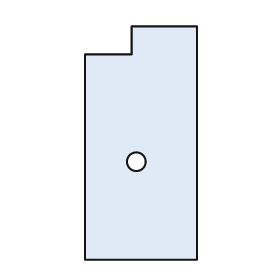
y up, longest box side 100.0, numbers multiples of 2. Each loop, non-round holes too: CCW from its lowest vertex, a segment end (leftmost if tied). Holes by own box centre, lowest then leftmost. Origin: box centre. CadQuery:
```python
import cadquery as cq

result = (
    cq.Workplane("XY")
    .moveTo(-24.0, -50.0)
    .lineTo(24.0, -50.0)
    .lineTo(24.0, 50.0)
    .lineTo(-4.0, 50.0)
    .lineTo(-4.0, 38.0)
    .lineTo(-24.0, 38.0)
    .close()
    .moveTo(-2.0, -8.0)
    .circle(4.0)
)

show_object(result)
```